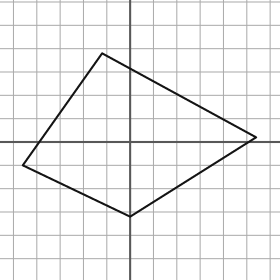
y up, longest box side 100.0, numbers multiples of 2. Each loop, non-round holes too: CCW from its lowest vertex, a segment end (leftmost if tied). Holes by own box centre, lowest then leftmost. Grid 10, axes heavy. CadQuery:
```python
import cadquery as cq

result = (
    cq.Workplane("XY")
    .moveTo(0.0, -32.0)
    .lineTo(54.0, 2.0)
    .lineTo(-12.0, 38.0)
    .lineTo(-46.0, -10.0)
    .close()
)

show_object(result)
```